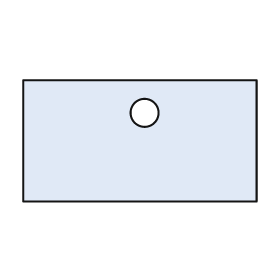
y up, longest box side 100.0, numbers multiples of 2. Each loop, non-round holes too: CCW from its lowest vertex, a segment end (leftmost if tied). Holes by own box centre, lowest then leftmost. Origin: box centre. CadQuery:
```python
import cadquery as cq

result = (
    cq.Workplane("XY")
    .moveTo(-50.0, -26.0)
    .lineTo(50.0, -26.0)
    .lineTo(50.0, 26.0)
    .lineTo(-50.0, 26.0)
    .close()
    .moveTo(2.0, 12.0)
    .circle(6.0)
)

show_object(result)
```